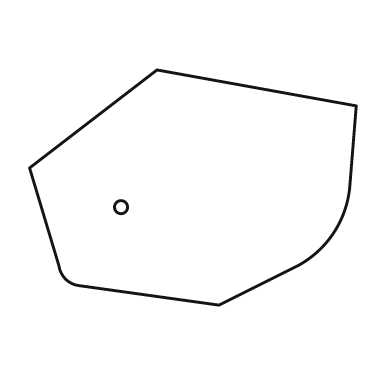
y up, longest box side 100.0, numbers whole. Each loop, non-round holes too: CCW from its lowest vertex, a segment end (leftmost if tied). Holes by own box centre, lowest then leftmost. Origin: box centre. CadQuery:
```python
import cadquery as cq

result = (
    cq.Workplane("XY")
    .moveTo(8.0, -36.0)
    .lineTo(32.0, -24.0)
    .threePointArc((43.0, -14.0), (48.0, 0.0))
    .lineTo(50.0, 25.0)
    .lineTo(-11.0, 36.0)
    .lineTo(-50.0, 6.0)
    .lineTo(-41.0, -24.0)
    .threePointArc((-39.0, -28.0), (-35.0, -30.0))
    .close()
    .moveTo(-22.0, -6.0)
    .circle(2.0)
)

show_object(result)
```